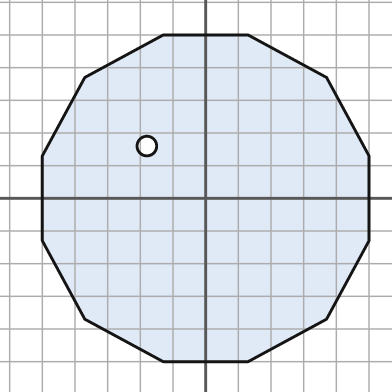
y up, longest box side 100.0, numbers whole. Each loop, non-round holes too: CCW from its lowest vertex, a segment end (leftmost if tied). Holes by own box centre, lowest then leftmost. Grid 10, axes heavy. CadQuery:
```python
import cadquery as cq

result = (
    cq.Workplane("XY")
    .moveTo(-13.0, -50.0)
    .lineTo(13.0, -50.0)
    .lineTo(37.0, -37.0)
    .lineTo(50.0, -13.0)
    .lineTo(50.0, 13.0)
    .lineTo(37.0, 37.0)
    .lineTo(13.0, 50.0)
    .lineTo(-13.0, 50.0)
    .lineTo(-37.0, 37.0)
    .lineTo(-50.0, 13.0)
    .lineTo(-50.0, -13.0)
    .lineTo(-37.0, -37.0)
    .close()
    .moveTo(-18.0, 16.0)
    .circle(3.0)
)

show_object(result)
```